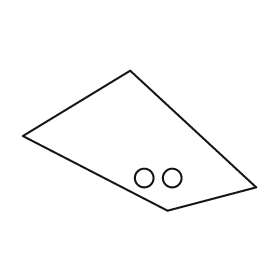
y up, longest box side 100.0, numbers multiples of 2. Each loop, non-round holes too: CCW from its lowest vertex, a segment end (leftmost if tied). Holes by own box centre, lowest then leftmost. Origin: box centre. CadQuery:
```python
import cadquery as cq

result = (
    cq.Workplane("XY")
    .moveTo(12.0, -30.0)
    .lineTo(50.0, -20.0)
    .lineTo(-4.0, 30.0)
    .lineTo(-50.0, 2.0)
    .close()
    .moveTo(2.0, -16.0)
    .circle(4.0)
    .moveTo(14.0, -16.0)
    .circle(4.0)
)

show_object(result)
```